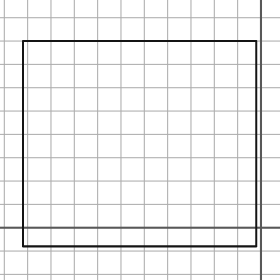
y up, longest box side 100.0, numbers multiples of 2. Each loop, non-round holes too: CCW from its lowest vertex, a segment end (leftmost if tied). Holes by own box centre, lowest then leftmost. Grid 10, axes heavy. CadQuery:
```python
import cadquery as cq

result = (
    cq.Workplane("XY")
    .moveTo(-102.0, -8.0)
    .lineTo(-2.0, -8.0)
    .lineTo(-2.0, 80.0)
    .lineTo(-102.0, 80.0)
    .close()
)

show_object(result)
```